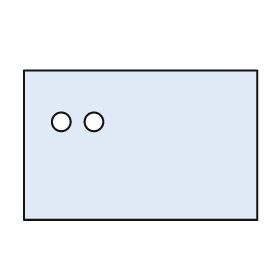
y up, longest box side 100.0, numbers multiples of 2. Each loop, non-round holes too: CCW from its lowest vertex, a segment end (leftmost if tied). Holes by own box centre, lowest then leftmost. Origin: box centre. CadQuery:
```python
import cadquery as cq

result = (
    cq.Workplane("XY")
    .moveTo(-50.0, -32.0)
    .lineTo(50.0, -32.0)
    .lineTo(50.0, 32.0)
    .lineTo(-50.0, 32.0)
    .close()
    .moveTo(-34.0, 10.0)
    .circle(4.0)
    .moveTo(-20.0, 10.0)
    .circle(4.0)
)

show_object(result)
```